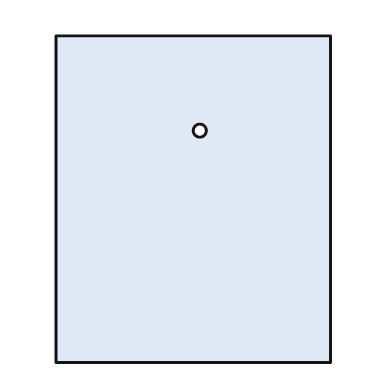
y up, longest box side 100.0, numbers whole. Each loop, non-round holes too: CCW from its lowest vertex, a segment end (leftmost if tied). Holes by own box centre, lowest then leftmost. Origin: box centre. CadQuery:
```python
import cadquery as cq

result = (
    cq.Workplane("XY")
    .moveTo(-42.0, -50.0)
    .lineTo(42.0, -50.0)
    .lineTo(42.0, 50.0)
    .lineTo(-42.0, 50.0)
    .close()
    .moveTo(2.0, 21.0)
    .circle(2.0)
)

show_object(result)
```